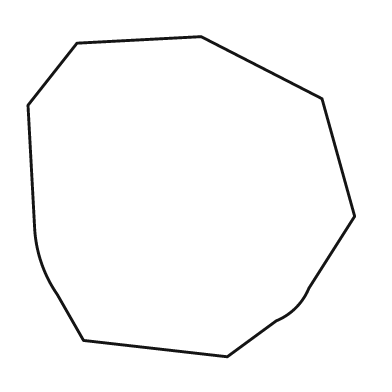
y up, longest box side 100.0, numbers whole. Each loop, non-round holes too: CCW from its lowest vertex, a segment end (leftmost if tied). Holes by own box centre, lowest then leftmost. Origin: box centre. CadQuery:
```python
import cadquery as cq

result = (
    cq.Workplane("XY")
    .moveTo(11.0, -49.0)
    .lineTo(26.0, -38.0)
    .threePointArc((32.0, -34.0), (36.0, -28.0))
    .lineTo(50.0, -6.0)
    .lineTo(40.0, 30.0)
    .lineTo(3.0, 49.0)
    .lineTo(-35.0, 47.0)
    .lineTo(-50.0, 28.0)
    .lineTo(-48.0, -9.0)
    .threePointArc((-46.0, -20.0), (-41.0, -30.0))
    .lineTo(-33.0, -44.0)
    .close()
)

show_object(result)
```